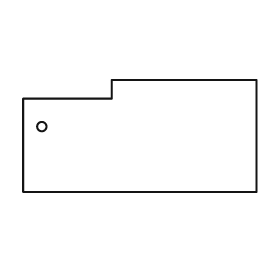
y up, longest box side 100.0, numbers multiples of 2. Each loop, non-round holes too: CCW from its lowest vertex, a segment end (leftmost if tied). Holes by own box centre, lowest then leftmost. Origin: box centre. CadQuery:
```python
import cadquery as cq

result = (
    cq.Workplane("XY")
    .moveTo(-50.0, -24.0)
    .lineTo(50.0, -24.0)
    .lineTo(50.0, 24.0)
    .lineTo(-12.0, 24.0)
    .lineTo(-12.0, 16.0)
    .lineTo(-50.0, 16.0)
    .close()
    .moveTo(-42.0, 4.0)
    .circle(2.0)
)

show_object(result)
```